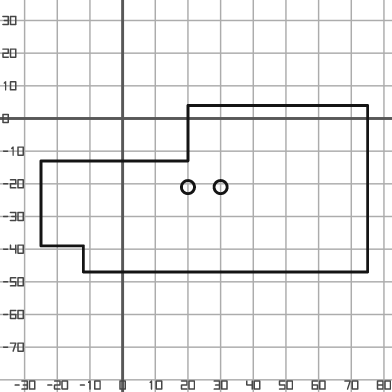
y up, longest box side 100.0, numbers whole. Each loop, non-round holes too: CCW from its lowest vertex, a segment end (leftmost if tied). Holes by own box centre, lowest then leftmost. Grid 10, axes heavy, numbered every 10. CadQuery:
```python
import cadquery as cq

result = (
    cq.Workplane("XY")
    .moveTo(-12.0, -47.0)
    .lineTo(75.0, -47.0)
    .lineTo(75.0, 4.0)
    .lineTo(20.0, 4.0)
    .lineTo(20.0, -13.0)
    .lineTo(-25.0, -13.0)
    .lineTo(-25.0, -39.0)
    .lineTo(-12.0, -39.0)
    .close()
    .moveTo(20.0, -21.0)
    .circle(2.0)
    .moveTo(30.0, -21.0)
    .circle(2.0)
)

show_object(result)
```